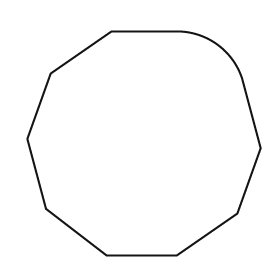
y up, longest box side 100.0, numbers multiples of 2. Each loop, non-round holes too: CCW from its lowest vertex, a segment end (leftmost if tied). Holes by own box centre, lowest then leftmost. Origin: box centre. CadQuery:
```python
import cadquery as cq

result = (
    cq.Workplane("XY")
    .moveTo(-16.0, -48.0)
    .lineTo(14.0, -48.0)
    .lineTo(40.0, -30.0)
    .lineTo(50.0, -2.0)
    .lineTo(42.0, 28.0)
    .threePointArc((32.0, 42.0), (16.0, 48.0))
    .lineTo(-14.0, 48.0)
    .lineTo(-40.0, 30.0)
    .lineTo(-50.0, 2.0)
    .lineTo(-42.0, -28.0)
    .close()
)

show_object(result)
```